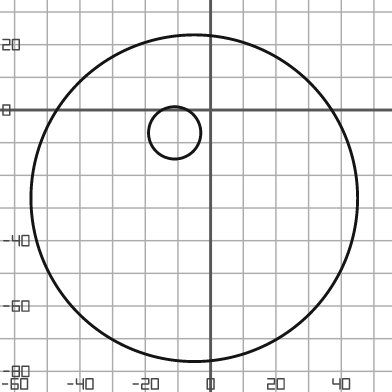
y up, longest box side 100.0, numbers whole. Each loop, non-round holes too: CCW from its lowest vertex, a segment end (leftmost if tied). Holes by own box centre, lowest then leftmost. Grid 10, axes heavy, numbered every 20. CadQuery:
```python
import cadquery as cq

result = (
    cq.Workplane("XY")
    .moveTo(-5.0, -27.0)
    .circle(50.0)
    .moveTo(-11.0, -7.0)
    .circle(8.0)
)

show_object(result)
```